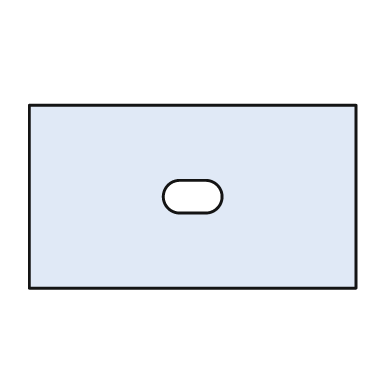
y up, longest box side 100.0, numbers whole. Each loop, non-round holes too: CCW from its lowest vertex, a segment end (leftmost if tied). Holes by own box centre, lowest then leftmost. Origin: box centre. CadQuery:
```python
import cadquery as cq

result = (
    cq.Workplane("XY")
    .moveTo(-50.0, -28.0)
    .lineTo(50.0, -28.0)
    .lineTo(50.0, 28.0)
    .lineTo(-50.0, 28.0)
    .close()
    .moveTo(-4.0, -5.0)
    .lineTo(4.0, -5.0)
    .threePointArc((9.0, 0.0), (4.0, 5.0))
    .lineTo(-4.0, 5.0)
    .threePointArc((-9.0, 0.0), (-4.0, -5.0))
    .close()
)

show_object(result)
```